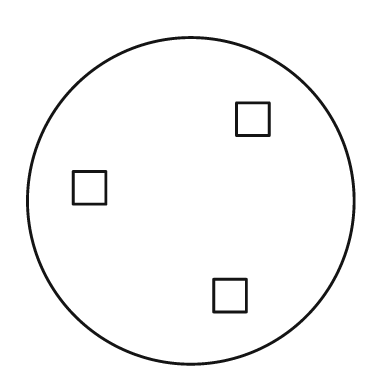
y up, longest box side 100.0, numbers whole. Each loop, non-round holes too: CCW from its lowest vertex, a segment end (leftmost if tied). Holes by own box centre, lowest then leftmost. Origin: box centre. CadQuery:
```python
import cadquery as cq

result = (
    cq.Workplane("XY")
    .moveTo(0.0, 0.0)
    .circle(50.0)
    .moveTo(7.0, -34.0)
    .lineTo(17.0, -34.0)
    .lineTo(17.0, -24.0)
    .lineTo(7.0, -24.0)
    .close()
    .moveTo(-36.0, -1.0)
    .lineTo(-26.0, -1.0)
    .lineTo(-26.0, 9.0)
    .lineTo(-36.0, 9.0)
    .close()
    .moveTo(14.0, 20.0)
    .lineTo(24.0, 20.0)
    .lineTo(24.0, 30.0)
    .lineTo(14.0, 30.0)
    .close()
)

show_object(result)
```